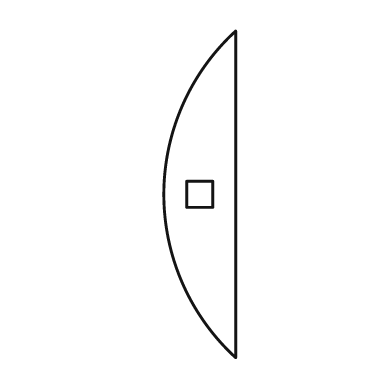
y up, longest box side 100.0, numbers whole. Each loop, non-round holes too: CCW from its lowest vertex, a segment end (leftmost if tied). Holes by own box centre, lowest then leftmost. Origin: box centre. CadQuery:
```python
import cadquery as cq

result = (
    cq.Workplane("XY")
    .moveTo(11.0, -50.0)
    .lineTo(11.0, 50.0)
    .threePointArc((-11.0, 0.0), (11.0, -50.0))
    .close()
    .moveTo(-4.0, -4.0)
    .lineTo(4.0, -4.0)
    .lineTo(4.0, 4.0)
    .lineTo(-4.0, 4.0)
    .close()
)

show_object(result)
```